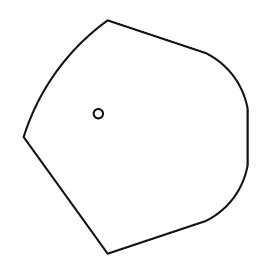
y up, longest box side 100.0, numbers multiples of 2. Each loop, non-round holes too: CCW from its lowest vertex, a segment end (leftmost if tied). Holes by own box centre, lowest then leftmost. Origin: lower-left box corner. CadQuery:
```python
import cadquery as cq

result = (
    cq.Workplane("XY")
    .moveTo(36.0, 0.0)
    .lineTo(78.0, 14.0)
    .threePointArc((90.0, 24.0), (96.0, 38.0))
    .lineTo(96.0, 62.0)
    .threePointArc((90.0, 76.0), (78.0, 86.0))
    .lineTo(36.0, 100.0)
    .threePointArc((14.0, 78.0), (0.0, 50.0))
    .close()
    .moveTo(32.0, 60.0)
    .circle(2.0)
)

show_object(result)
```